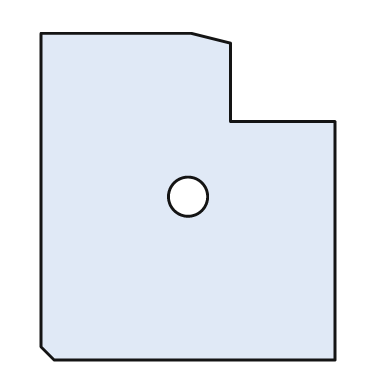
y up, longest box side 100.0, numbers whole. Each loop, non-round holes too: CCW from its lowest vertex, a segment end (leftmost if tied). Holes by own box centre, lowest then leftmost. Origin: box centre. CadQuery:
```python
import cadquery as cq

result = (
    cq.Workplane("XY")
    .moveTo(-41.0, -50.0)
    .lineTo(45.0, -50.0)
    .lineTo(45.0, 23.0)
    .lineTo(13.0, 23.0)
    .lineTo(13.0, 47.0)
    .lineTo(1.0, 50.0)
    .lineTo(-45.0, 50.0)
    .lineTo(-45.0, -46.0)
    .close()
    .moveTo(0.0, 0.0)
    .circle(6.0)
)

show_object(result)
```